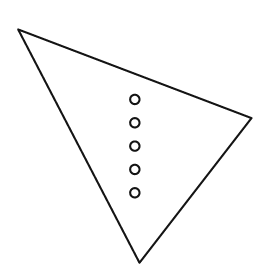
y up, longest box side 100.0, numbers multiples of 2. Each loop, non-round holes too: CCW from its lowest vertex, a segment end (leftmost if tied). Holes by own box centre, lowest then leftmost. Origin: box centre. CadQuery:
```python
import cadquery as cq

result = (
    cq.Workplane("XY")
    .moveTo(2.0, -50.0)
    .lineTo(50.0, 12.0)
    .lineTo(-50.0, 50.0)
    .close()
    .moveTo(0.0, -20.0)
    .circle(2.0)
    .moveTo(0.0, -10.0)
    .circle(2.0)
    .moveTo(0.0, 0.0)
    .circle(2.0)
    .moveTo(0.0, 10.0)
    .circle(2.0)
    .moveTo(0.0, 20.0)
    .circle(2.0)
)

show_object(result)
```